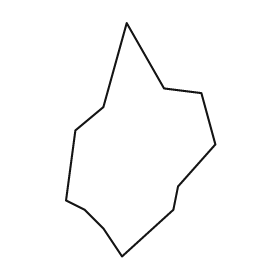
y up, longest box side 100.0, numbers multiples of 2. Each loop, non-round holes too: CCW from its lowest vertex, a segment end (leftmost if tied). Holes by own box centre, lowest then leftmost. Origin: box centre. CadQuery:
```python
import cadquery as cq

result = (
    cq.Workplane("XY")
    .moveTo(-8.0, -50.0)
    .lineTo(14.0, -30.0)
    .lineTo(16.0, -20.0)
    .lineTo(32.0, -2.0)
    .lineTo(26.0, 20.0)
    .lineTo(10.0, 22.0)
    .lineTo(-6.0, 50.0)
    .lineTo(-16.0, 14.0)
    .lineTo(-28.0, 4.0)
    .lineTo(-32.0, -26.0)
    .lineTo(-24.0, -30.0)
    .lineTo(-16.0, -38.0)
    .close()
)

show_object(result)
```